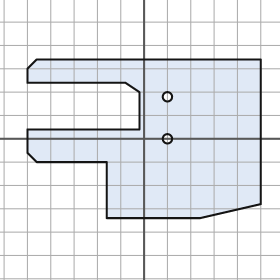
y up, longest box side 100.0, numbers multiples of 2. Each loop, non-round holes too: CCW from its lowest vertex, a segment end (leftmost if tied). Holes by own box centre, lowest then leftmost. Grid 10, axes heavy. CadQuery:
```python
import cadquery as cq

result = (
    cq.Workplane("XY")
    .moveTo(-16.0, -34.0)
    .lineTo(24.0, -34.0)
    .lineTo(50.0, -28.0)
    .lineTo(50.0, 34.0)
    .lineTo(-46.0, 34.0)
    .lineTo(-50.0, 30.0)
    .lineTo(-50.0, 24.0)
    .lineTo(-8.0, 24.0)
    .lineTo(-2.0, 20.0)
    .lineTo(-2.0, 4.0)
    .lineTo(-50.0, 4.0)
    .lineTo(-50.0, -6.0)
    .lineTo(-46.0, -10.0)
    .lineTo(-16.0, -10.0)
    .close()
    .moveTo(10.0, 0.0)
    .circle(2.0)
    .moveTo(10.0, 18.0)
    .circle(2.0)
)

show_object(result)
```